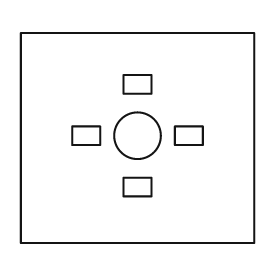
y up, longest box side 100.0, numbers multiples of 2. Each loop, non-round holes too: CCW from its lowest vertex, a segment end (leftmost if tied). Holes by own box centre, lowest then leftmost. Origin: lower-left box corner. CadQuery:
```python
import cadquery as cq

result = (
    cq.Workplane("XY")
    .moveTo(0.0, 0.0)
    .lineTo(100.0, 0.0)
    .lineTo(100.0, 90.0)
    .lineTo(0.0, 90.0)
    .close()
    .moveTo(44.0, 20.0)
    .lineTo(56.0, 20.0)
    .lineTo(56.0, 28.0)
    .lineTo(44.0, 28.0)
    .close()
    .moveTo(22.0, 42.0)
    .lineTo(34.0, 42.0)
    .lineTo(34.0, 50.0)
    .lineTo(22.0, 50.0)
    .close()
    .moveTo(50.0, 46.0)
    .circle(10.0)
    .moveTo(66.0, 42.0)
    .lineTo(78.0, 42.0)
    .lineTo(78.0, 50.0)
    .lineTo(66.0, 50.0)
    .close()
    .moveTo(44.0, 64.0)
    .lineTo(56.0, 64.0)
    .lineTo(56.0, 72.0)
    .lineTo(44.0, 72.0)
    .close()
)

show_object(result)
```